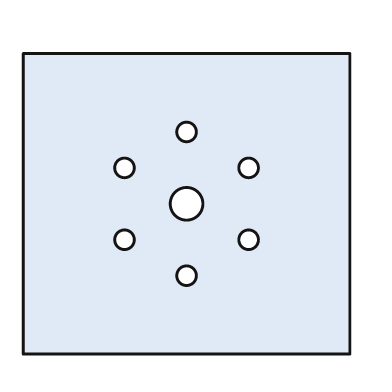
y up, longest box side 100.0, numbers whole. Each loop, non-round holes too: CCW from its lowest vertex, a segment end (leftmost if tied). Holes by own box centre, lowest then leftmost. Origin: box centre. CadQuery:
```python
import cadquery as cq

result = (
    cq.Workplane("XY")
    .moveTo(-50.0, -46.0)
    .lineTo(50.0, -46.0)
    .lineTo(50.0, 46.0)
    .lineTo(-50.0, 46.0)
    .close()
    .moveTo(0.0, -22.0)
    .circle(3.0)
    .moveTo(-19.0, -11.0)
    .circle(3.0)
    .moveTo(19.0, -11.0)
    .circle(3.0)
    .moveTo(0.0, 0.0)
    .circle(5.0)
    .moveTo(-19.0, 11.0)
    .circle(3.0)
    .moveTo(19.0, 11.0)
    .circle(3.0)
    .moveTo(0.0, 22.0)
    .circle(3.0)
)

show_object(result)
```